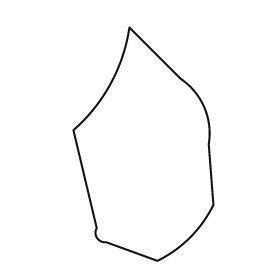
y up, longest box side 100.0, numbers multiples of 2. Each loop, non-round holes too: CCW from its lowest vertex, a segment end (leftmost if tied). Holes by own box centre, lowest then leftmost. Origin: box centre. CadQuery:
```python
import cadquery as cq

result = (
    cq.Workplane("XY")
    .moveTo(6.0, -50.0)
    .threePointArc((20.0, -40.0), (30.0, -26.0))
    .lineTo(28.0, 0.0)
    .threePointArc((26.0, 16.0), (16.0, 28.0))
    .lineTo(-6.0, 50.0)
    .threePointArc((-14.0, 26.0), (-30.0, 6.0))
    .lineTo(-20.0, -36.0)
    .threePointArc((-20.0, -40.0), (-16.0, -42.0))
    .close()
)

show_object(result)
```